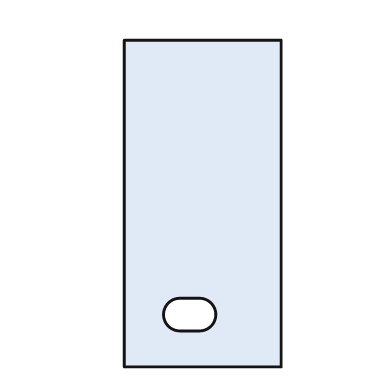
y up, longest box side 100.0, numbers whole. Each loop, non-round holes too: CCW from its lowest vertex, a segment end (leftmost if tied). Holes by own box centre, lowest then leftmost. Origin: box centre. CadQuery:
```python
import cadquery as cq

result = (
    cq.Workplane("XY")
    .moveTo(-24.0, -50.0)
    .lineTo(24.0, -50.0)
    .lineTo(24.0, 50.0)
    .lineTo(-24.0, 50.0)
    .close()
    .moveTo(-7.0, -39.0)
    .lineTo(-1.0, -39.0)
    .threePointArc((4.0, -34.0), (-1.0, -29.0))
    .lineTo(-7.0, -29.0)
    .threePointArc((-12.0, -34.0), (-7.0, -39.0))
    .close()
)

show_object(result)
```